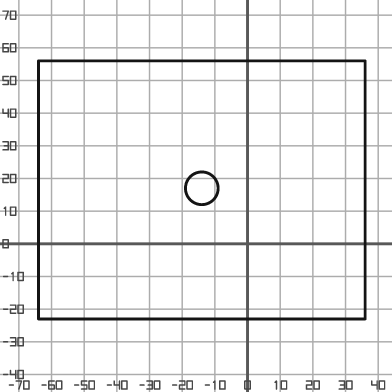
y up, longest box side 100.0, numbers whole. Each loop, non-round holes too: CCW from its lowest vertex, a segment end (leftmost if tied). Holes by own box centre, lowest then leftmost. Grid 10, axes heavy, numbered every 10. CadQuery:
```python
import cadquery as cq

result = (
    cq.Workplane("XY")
    .moveTo(-64.0, -23.0)
    .lineTo(36.0, -23.0)
    .lineTo(36.0, 56.0)
    .lineTo(-64.0, 56.0)
    .close()
    .moveTo(-14.0, 17.0)
    .circle(5.0)
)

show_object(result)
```